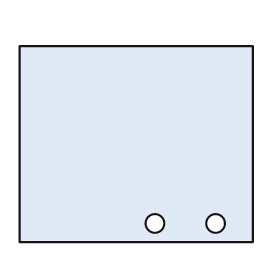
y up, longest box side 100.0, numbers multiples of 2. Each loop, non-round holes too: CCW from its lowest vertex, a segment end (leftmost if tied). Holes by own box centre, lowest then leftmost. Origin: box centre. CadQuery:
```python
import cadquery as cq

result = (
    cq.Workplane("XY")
    .moveTo(-50.0, -42.0)
    .lineTo(50.0, -42.0)
    .lineTo(50.0, 42.0)
    .lineTo(-50.0, 42.0)
    .close()
    .moveTo(8.0, -34.0)
    .circle(4.0)
    .moveTo(34.0, -34.0)
    .circle(4.0)
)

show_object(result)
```